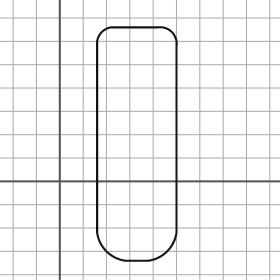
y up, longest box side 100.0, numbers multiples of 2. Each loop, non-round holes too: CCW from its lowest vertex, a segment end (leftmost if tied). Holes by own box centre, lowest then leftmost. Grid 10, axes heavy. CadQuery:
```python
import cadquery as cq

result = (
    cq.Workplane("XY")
    .moveTo(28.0, -34.0)
    .lineTo(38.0, -34.0)
    .threePointArc((46.0, -30.0), (50.0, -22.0))
    .lineTo(50.0, 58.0)
    .threePointArc((48.0, 64.0), (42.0, 66.0))
    .lineTo(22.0, 66.0)
    .threePointArc((18.0, 64.0), (16.0, 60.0))
    .lineTo(16.0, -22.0)
    .threePointArc((20.0, -30.0), (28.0, -34.0))
    .close()
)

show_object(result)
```